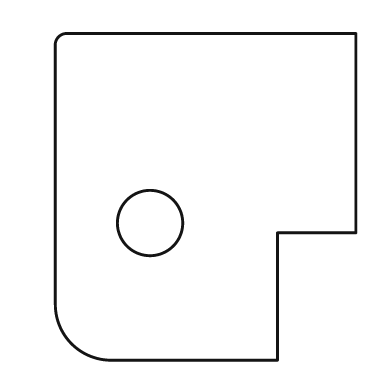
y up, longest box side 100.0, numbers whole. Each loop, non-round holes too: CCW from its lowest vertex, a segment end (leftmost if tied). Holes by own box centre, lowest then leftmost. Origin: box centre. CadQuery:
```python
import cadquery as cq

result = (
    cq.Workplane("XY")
    .moveTo(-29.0, -50.0)
    .lineTo(22.0, -50.0)
    .lineTo(22.0, -11.0)
    .lineTo(46.0, -11.0)
    .lineTo(46.0, 50.0)
    .lineTo(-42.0, 50.0)
    .threePointArc((-45.0, 49.0), (-46.0, 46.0))
    .lineTo(-46.0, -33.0)
    .threePointArc((-41.0, -45.0), (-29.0, -50.0))
    .close()
    .moveTo(-17.0, -8.0)
    .circle(10.0)
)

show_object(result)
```